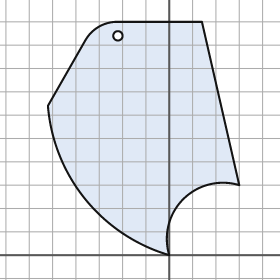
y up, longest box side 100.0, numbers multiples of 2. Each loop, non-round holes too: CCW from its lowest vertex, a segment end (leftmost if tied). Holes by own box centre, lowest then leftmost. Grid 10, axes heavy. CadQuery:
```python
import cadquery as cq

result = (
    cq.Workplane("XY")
    .moveTo(0.0, 0.0)
    .threePointArc((6.0, 24.0), (30.0, 30.0))
    .lineTo(14.0, 100.0)
    .lineTo(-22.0, 100.0)
    .threePointArc((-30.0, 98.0), (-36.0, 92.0))
    .lineTo(-52.0, 64.0)
    .threePointArc((-36.0, 24.0), (0.0, 0.0))
    .close()
    .moveTo(-22.0, 94.0)
    .circle(2.0)
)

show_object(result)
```